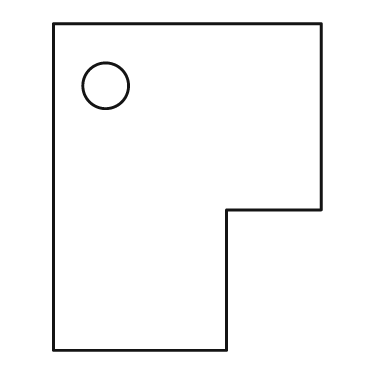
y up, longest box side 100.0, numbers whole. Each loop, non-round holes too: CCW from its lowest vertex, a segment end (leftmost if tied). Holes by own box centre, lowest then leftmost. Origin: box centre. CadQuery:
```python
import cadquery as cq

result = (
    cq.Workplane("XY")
    .moveTo(-41.0, -50.0)
    .lineTo(12.0, -50.0)
    .lineTo(12.0, -7.0)
    .lineTo(41.0, -7.0)
    .lineTo(41.0, 50.0)
    .lineTo(-41.0, 50.0)
    .close()
    .moveTo(-25.0, 31.0)
    .circle(7.0)
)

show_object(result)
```